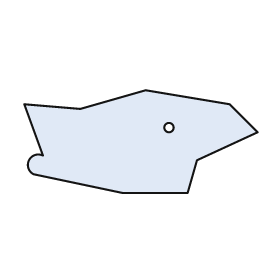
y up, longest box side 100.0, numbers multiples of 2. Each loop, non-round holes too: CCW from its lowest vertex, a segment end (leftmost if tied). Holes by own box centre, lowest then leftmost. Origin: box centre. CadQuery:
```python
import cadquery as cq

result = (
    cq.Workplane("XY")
    .moveTo(-8.0, -22.0)
    .lineTo(20.0, -22.0)
    .lineTo(24.0, -8.0)
    .lineTo(50.0, 4.0)
    .lineTo(38.0, 16.0)
    .lineTo(2.0, 22.0)
    .lineTo(-26.0, 14.0)
    .lineTo(-50.0, 16.0)
    .lineTo(-42.0, -6.0)
    .threePointArc((-48.0, -8.0), (-46.0, -14.0))
    .close()
    .moveTo(12.0, 6.0)
    .circle(2.0)
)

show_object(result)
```